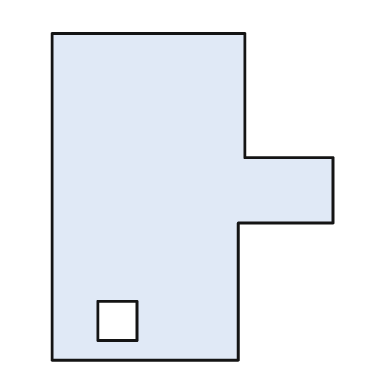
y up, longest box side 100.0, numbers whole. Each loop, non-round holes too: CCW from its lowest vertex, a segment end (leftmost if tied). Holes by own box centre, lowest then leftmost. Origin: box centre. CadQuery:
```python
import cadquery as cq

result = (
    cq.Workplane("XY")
    .moveTo(-43.0, -50.0)
    .lineTo(14.0, -50.0)
    .lineTo(14.0, -8.0)
    .lineTo(43.0, -8.0)
    .lineTo(43.0, 12.0)
    .lineTo(16.0, 12.0)
    .lineTo(16.0, 50.0)
    .lineTo(-43.0, 50.0)
    .close()
    .moveTo(-29.0, -44.0)
    .lineTo(-17.0, -44.0)
    .lineTo(-17.0, -32.0)
    .lineTo(-29.0, -32.0)
    .close()
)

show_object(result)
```